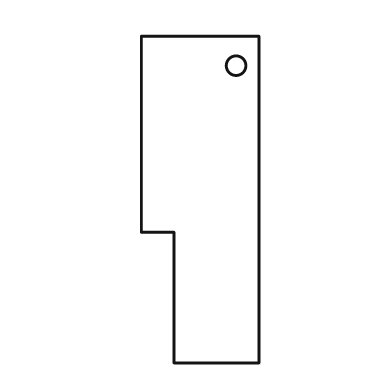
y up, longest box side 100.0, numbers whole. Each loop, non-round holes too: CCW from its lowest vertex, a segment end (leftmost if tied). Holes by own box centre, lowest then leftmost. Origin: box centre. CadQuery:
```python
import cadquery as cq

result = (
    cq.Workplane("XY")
    .moveTo(-8.0, -50.0)
    .lineTo(18.0, -50.0)
    .lineTo(18.0, 50.0)
    .lineTo(-18.0, 50.0)
    .lineTo(-18.0, -10.0)
    .lineTo(-8.0, -10.0)
    .close()
    .moveTo(11.0, 41.0)
    .circle(3.0)
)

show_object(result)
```